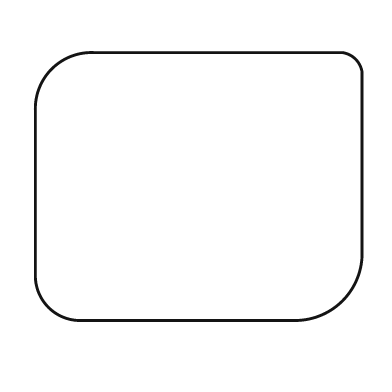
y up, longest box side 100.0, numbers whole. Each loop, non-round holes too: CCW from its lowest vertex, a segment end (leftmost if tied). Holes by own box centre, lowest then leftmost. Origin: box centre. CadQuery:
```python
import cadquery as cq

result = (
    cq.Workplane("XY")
    .moveTo(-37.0, -41.0)
    .lineTo(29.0, -41.0)
    .threePointArc((44.0, -35.0), (50.0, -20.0))
    .lineTo(50.0, 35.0)
    .threePointArc((48.0, 39.0), (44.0, 41.0))
    .lineTo(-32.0, 41.0)
    .threePointArc((-45.0, 36.0), (-50.0, 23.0))
    .lineTo(-50.0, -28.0)
    .threePointArc((-46.0, -37.0), (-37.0, -41.0))
    .close()
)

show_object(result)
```